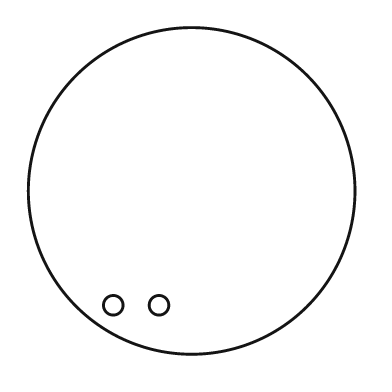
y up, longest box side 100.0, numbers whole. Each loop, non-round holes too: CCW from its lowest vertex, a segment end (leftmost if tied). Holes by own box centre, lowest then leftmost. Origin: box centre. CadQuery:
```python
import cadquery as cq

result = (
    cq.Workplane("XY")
    .moveTo(0.0, 0.0)
    .circle(50.0)
    .moveTo(-24.0, -35.0)
    .circle(3.0)
    .moveTo(-10.0, -35.0)
    .circle(3.0)
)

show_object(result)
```